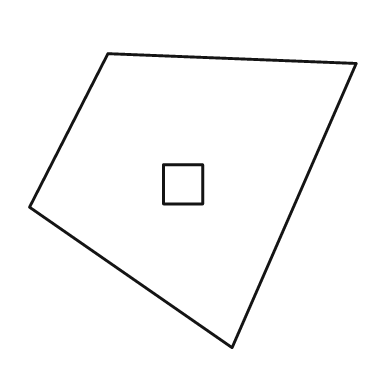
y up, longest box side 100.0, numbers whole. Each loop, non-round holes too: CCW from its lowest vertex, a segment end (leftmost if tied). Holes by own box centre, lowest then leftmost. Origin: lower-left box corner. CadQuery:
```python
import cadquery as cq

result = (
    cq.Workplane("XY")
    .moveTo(62.0, 0.0)
    .lineTo(100.0, 87.0)
    .lineTo(24.0, 90.0)
    .lineTo(0.0, 43.0)
    .close()
    .moveTo(41.0, 44.0)
    .lineTo(53.0, 44.0)
    .lineTo(53.0, 56.0)
    .lineTo(41.0, 56.0)
    .close()
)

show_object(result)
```